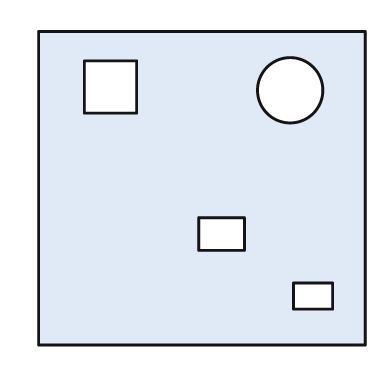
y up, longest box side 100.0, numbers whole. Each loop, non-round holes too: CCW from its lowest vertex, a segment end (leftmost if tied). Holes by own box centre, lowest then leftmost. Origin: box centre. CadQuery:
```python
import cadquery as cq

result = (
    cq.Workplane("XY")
    .moveTo(-50.0, -48.0)
    .lineTo(50.0, -48.0)
    .lineTo(50.0, 48.0)
    .lineTo(-50.0, 48.0)
    .close()
    .moveTo(28.0, -37.0)
    .lineTo(40.0, -37.0)
    .lineTo(40.0, -29.0)
    .lineTo(28.0, -29.0)
    .close()
    .moveTo(-1.0, -19.0)
    .lineTo(13.0, -19.0)
    .lineTo(13.0, -9.0)
    .lineTo(-1.0, -9.0)
    .close()
    .moveTo(27.0, 30.0)
    .circle(10.0)
    .moveTo(-36.0, 23.0)
    .lineTo(-20.0, 23.0)
    .lineTo(-20.0, 39.0)
    .lineTo(-36.0, 39.0)
    .close()
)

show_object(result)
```